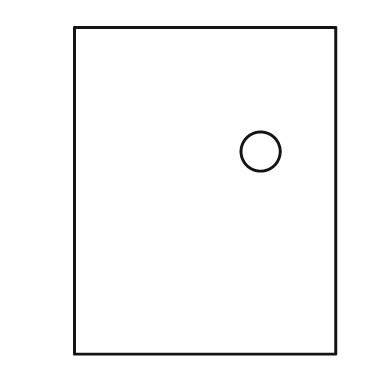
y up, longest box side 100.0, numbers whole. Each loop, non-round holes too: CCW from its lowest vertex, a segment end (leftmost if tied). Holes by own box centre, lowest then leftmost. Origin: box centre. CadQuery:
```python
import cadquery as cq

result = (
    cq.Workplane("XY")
    .moveTo(-40.0, -50.0)
    .lineTo(40.0, -50.0)
    .lineTo(40.0, 50.0)
    .lineTo(-40.0, 50.0)
    .close()
    .moveTo(17.0, 12.0)
    .circle(6.0)
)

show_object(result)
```